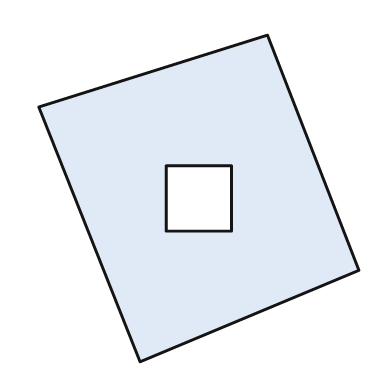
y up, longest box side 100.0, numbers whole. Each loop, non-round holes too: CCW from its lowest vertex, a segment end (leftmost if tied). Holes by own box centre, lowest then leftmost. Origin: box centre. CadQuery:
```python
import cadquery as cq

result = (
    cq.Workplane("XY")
    .moveTo(-18.0, -50.0)
    .lineTo(49.0, -22.0)
    .lineTo(21.0, 50.0)
    .lineTo(-49.0, 28.0)
    .close()
    .moveTo(-10.0, -10.0)
    .lineTo(10.0, -10.0)
    .lineTo(10.0, 10.0)
    .lineTo(-10.0, 10.0)
    .close()
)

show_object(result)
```